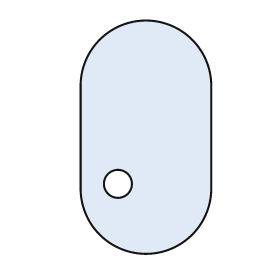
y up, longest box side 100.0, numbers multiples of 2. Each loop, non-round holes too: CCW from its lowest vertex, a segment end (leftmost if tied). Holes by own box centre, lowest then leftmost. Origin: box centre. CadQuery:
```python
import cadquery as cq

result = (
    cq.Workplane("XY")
    .moveTo(-28.0, -22.0)
    .threePointArc((0.0, -50.0), (28.0, -22.0))
    .lineTo(28.0, 22.0)
    .threePointArc((0.0, 50.0), (-28.0, 22.0))
    .close()
    .moveTo(-12.0, -20.0)
    .circle(6.0)
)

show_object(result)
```